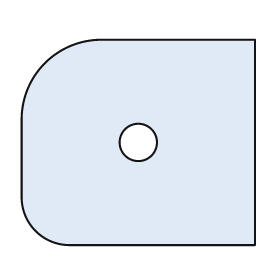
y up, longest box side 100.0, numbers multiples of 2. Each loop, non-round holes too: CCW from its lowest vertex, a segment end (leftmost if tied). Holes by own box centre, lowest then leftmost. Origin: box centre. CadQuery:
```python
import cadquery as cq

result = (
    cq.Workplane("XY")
    .moveTo(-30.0, -44.0)
    .lineTo(50.0, -44.0)
    .lineTo(50.0, 44.0)
    .lineTo(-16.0, 44.0)
    .threePointArc((-40.0, 34.0), (-50.0, 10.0))
    .lineTo(-50.0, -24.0)
    .threePointArc((-44.0, -38.0), (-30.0, -44.0))
    .close()
    .moveTo(0.0, 0.0)
    .circle(8.0)
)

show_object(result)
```